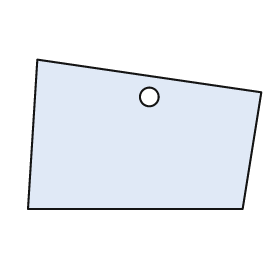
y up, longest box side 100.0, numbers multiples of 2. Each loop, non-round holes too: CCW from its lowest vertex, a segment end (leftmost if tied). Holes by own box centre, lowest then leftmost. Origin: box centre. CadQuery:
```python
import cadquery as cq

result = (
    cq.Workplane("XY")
    .moveTo(-50.0, -32.0)
    .lineTo(42.0, -32.0)
    .lineTo(50.0, 18.0)
    .lineTo(-46.0, 32.0)
    .close()
    .moveTo(2.0, 16.0)
    .circle(4.0)
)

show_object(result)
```